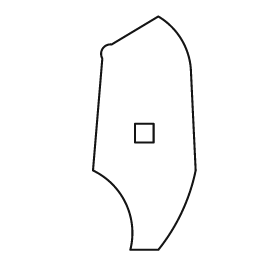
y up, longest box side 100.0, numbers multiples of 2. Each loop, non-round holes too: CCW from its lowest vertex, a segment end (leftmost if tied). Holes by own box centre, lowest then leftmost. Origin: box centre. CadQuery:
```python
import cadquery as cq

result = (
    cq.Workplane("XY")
    .moveTo(-6.0, -50.0)
    .lineTo(6.0, -50.0)
    .threePointArc((16.0, -34.0), (22.0, -16.0))
    .lineTo(20.0, 26.0)
    .threePointArc((16.0, 40.0), (6.0, 50.0))
    .lineTo(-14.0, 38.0)
    .threePointArc((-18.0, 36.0), (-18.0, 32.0))
    .lineTo(-22.0, -16.0)
    .threePointArc((-8.0, -30.0), (-6.0, -50.0))
    .close()
    .moveTo(-4.0, -4.0)
    .lineTo(4.0, -4.0)
    .lineTo(4.0, 4.0)
    .lineTo(-4.0, 4.0)
    .close()
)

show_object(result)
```